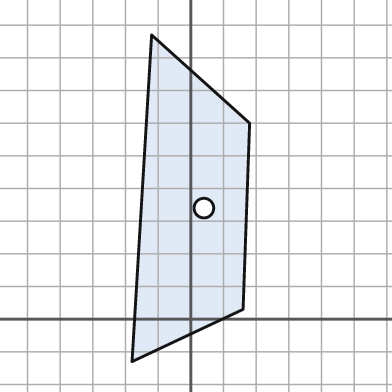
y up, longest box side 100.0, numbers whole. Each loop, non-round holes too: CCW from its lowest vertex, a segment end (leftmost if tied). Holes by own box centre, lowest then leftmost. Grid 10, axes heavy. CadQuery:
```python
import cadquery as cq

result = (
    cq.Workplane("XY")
    .moveTo(-18.0, -13.0)
    .lineTo(16.0, 3.0)
    .lineTo(18.0, 60.0)
    .lineTo(-12.0, 87.0)
    .close()
    .moveTo(4.0, 34.0)
    .circle(3.0)
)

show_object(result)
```